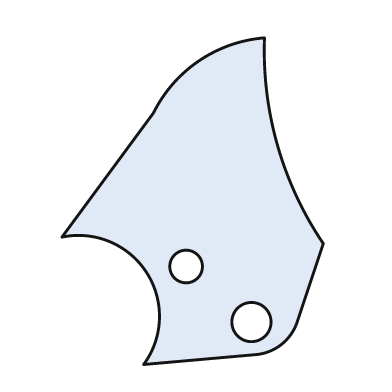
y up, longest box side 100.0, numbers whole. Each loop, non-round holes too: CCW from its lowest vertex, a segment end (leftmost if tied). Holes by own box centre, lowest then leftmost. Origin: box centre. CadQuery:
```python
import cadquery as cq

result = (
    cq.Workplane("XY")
    .moveTo(-15.0, -50.0)
    .lineTo(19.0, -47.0)
    .threePointArc((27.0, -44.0), (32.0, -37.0))
    .lineTo(40.0, -13.0)
    .threePointArc((26.0, 17.0), (22.0, 50.0))
    .threePointArc((2.0, 43.0), (-12.0, 27.0))
    .lineTo(-40.0, -11.0)
    .threePointArc((-14.0, -22.0), (-15.0, -50.0))
    .close()
    .moveTo(18.0, -37.0)
    .circle(6.0)
    .moveTo(-2.0, -20.0)
    .circle(5.0)
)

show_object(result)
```